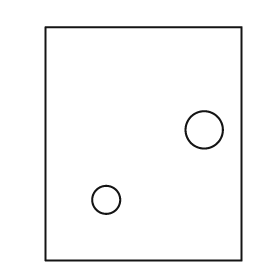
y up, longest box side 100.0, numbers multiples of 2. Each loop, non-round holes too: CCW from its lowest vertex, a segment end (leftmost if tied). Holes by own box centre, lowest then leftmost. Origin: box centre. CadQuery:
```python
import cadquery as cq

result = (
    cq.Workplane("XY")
    .moveTo(-42.0, -50.0)
    .lineTo(42.0, -50.0)
    .lineTo(42.0, 50.0)
    .lineTo(-42.0, 50.0)
    .close()
    .moveTo(-16.0, -24.0)
    .circle(6.0)
    .moveTo(26.0, 6.0)
    .circle(8.0)
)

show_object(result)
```